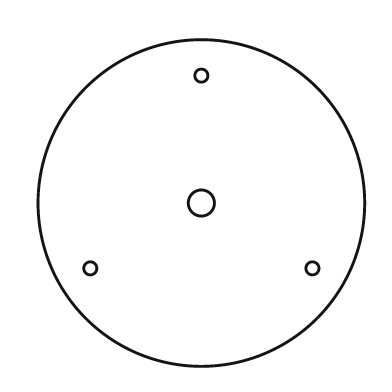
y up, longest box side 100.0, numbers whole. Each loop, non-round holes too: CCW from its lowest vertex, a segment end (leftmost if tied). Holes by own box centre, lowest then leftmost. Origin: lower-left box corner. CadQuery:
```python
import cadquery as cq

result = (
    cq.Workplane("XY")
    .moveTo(50.0, 50.0)
    .circle(50.0)
    .moveTo(16.0, 30.0)
    .circle(2.0)
    .moveTo(84.0, 30.0)
    .circle(2.0)
    .moveTo(50.0, 50.0)
    .circle(4.0)
    .moveTo(50.0, 89.0)
    .circle(2.0)
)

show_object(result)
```